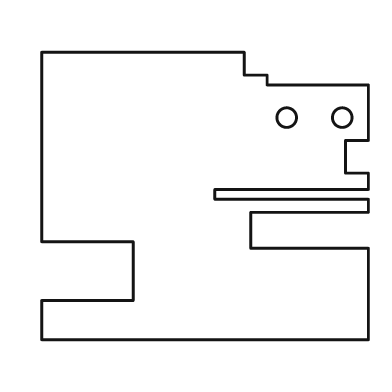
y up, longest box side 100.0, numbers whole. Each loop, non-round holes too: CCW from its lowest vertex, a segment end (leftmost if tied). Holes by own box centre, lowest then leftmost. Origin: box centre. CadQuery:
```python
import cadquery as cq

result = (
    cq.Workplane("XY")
    .moveTo(-50.0, -44.0)
    .lineTo(50.0, -44.0)
    .lineTo(50.0, -16.0)
    .lineTo(14.0, -16.0)
    .lineTo(14.0, -5.0)
    .lineTo(50.0, -5.0)
    .lineTo(50.0, -1.0)
    .lineTo(3.0, -1.0)
    .lineTo(3.0, 2.0)
    .lineTo(50.0, 2.0)
    .lineTo(50.0, 7.0)
    .lineTo(43.0, 7.0)
    .lineTo(43.0, 17.0)
    .lineTo(50.0, 17.0)
    .lineTo(50.0, 34.0)
    .lineTo(19.0, 34.0)
    .lineTo(19.0, 37.0)
    .lineTo(12.0, 37.0)
    .lineTo(12.0, 44.0)
    .lineTo(-50.0, 44.0)
    .lineTo(-50.0, -14.0)
    .lineTo(-22.0, -14.0)
    .lineTo(-22.0, -32.0)
    .lineTo(-50.0, -32.0)
    .close()
    .moveTo(25.0, 24.0)
    .circle(3.0)
    .moveTo(42.0, 24.0)
    .circle(3.0)
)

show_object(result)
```